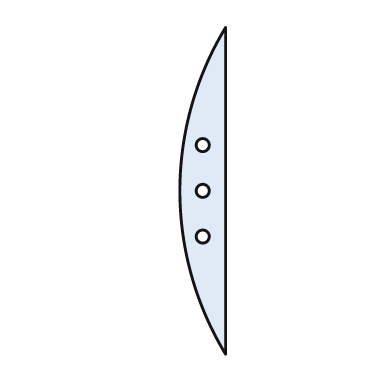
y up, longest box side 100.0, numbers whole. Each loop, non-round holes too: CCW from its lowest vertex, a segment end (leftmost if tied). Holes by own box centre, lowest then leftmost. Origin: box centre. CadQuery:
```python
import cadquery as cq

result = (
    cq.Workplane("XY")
    .moveTo(7.0, -50.0)
    .lineTo(7.0, 50.0)
    .threePointArc((-7.0, 0.0), (7.0, -50.0))
    .close()
    .moveTo(0.0, -14.0)
    .circle(2.0)
    .moveTo(0.0, 0.0)
    .circle(2.0)
    .moveTo(0.0, 14.0)
    .circle(2.0)
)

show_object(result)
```